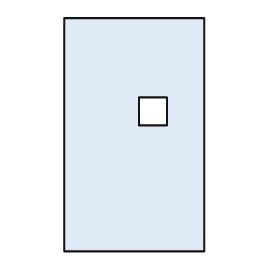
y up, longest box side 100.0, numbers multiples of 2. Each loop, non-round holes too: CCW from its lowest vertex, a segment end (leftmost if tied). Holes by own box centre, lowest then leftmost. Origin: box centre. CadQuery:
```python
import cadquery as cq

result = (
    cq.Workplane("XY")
    .moveTo(-30.0, -50.0)
    .lineTo(30.0, -50.0)
    .lineTo(30.0, 50.0)
    .lineTo(-30.0, 50.0)
    .close()
    .moveTo(2.0, 4.0)
    .lineTo(14.0, 4.0)
    .lineTo(14.0, 16.0)
    .lineTo(2.0, 16.0)
    .close()
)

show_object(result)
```